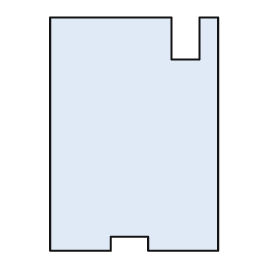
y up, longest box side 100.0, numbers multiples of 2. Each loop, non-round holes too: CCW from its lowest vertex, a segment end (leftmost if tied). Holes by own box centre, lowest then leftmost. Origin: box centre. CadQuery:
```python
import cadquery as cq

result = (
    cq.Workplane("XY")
    .moveTo(-36.0, -50.0)
    .lineTo(-10.0, -50.0)
    .lineTo(-10.0, -44.0)
    .lineTo(6.0, -44.0)
    .lineTo(6.0, -50.0)
    .lineTo(36.0, -50.0)
    .lineTo(36.0, 50.0)
    .lineTo(28.0, 50.0)
    .lineTo(28.0, 32.0)
    .lineTo(16.0, 32.0)
    .lineTo(16.0, 50.0)
    .lineTo(-36.0, 50.0)
    .close()
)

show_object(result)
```